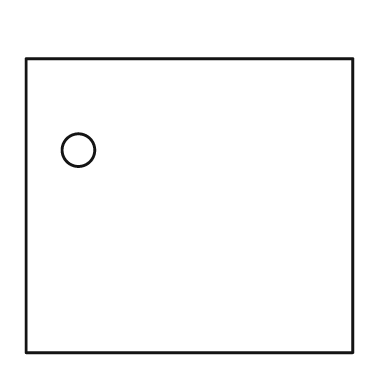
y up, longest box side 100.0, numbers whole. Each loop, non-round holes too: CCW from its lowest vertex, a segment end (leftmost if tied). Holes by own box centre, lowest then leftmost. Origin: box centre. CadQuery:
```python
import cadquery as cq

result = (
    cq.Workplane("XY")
    .moveTo(-50.0, -45.0)
    .lineTo(50.0, -45.0)
    .lineTo(50.0, 45.0)
    .lineTo(-50.0, 45.0)
    .close()
    .moveTo(-34.0, 17.0)
    .circle(5.0)
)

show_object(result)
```